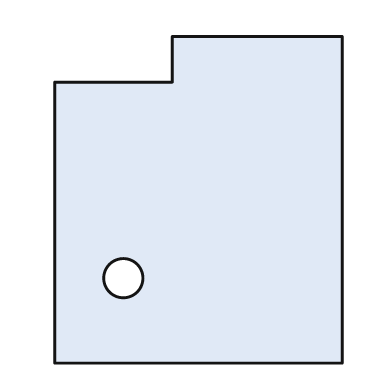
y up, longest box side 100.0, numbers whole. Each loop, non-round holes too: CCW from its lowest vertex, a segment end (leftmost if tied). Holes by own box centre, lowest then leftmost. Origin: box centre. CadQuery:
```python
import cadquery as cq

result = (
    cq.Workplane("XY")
    .moveTo(-44.0, -50.0)
    .lineTo(44.0, -50.0)
    .lineTo(44.0, 50.0)
    .lineTo(-8.0, 50.0)
    .lineTo(-8.0, 36.0)
    .lineTo(-44.0, 36.0)
    .close()
    .moveTo(-23.0, -24.0)
    .circle(6.0)
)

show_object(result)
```